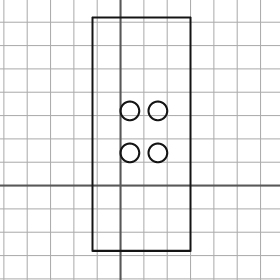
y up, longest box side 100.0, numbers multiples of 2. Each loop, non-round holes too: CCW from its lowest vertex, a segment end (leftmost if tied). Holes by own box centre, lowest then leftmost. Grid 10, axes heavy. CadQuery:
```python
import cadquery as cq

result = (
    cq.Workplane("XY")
    .moveTo(-12.0, -28.0)
    .lineTo(30.0, -28.0)
    .lineTo(30.0, 72.0)
    .lineTo(-12.0, 72.0)
    .close()
    .moveTo(4.0, 14.0)
    .circle(4.0)
    .moveTo(16.0, 14.0)
    .circle(4.0)
    .moveTo(4.0, 32.0)
    .circle(4.0)
    .moveTo(16.0, 32.0)
    .circle(4.0)
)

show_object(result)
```